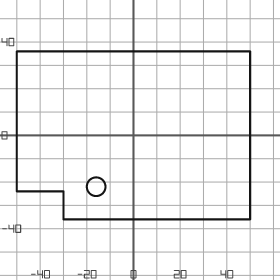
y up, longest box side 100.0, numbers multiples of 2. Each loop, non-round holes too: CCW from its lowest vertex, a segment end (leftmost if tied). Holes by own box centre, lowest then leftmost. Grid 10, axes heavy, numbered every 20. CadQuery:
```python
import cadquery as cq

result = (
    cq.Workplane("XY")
    .moveTo(-30.0, -36.0)
    .lineTo(50.0, -36.0)
    .lineTo(50.0, 36.0)
    .lineTo(-50.0, 36.0)
    .lineTo(-50.0, -24.0)
    .lineTo(-30.0, -24.0)
    .close()
    .moveTo(-16.0, -22.0)
    .circle(4.0)
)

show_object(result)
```